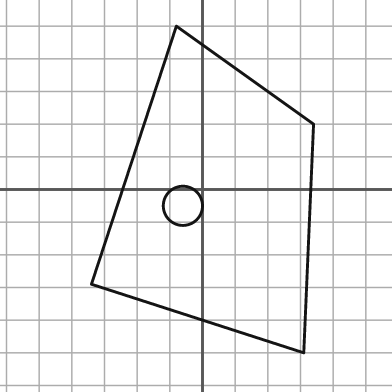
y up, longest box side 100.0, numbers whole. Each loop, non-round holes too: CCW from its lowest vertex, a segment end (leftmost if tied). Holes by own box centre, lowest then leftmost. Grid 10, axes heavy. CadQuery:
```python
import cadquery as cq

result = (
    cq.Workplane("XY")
    .moveTo(31.0, -50.0)
    .lineTo(34.0, 20.0)
    .lineTo(-8.0, 50.0)
    .lineTo(-34.0, -29.0)
    .close()
    .moveTo(-6.0, -5.0)
    .circle(6.0)
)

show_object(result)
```